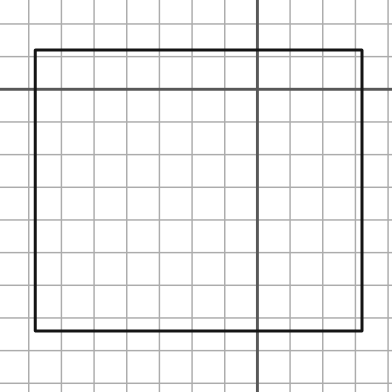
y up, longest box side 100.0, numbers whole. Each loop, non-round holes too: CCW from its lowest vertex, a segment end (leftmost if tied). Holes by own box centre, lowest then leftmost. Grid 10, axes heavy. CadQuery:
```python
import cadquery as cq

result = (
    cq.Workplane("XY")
    .moveTo(-68.0, -74.0)
    .lineTo(32.0, -74.0)
    .lineTo(32.0, 12.0)
    .lineTo(-68.0, 12.0)
    .close()
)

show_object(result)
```